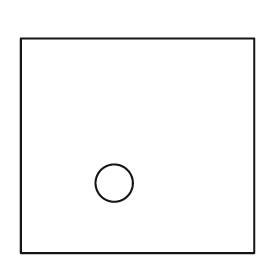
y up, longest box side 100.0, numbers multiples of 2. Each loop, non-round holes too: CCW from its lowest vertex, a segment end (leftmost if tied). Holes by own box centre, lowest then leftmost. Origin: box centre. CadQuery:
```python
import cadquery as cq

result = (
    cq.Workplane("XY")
    .moveTo(-50.0, -46.0)
    .lineTo(50.0, -46.0)
    .lineTo(50.0, 46.0)
    .lineTo(-50.0, 46.0)
    .close()
    .moveTo(-10.0, -16.0)
    .circle(8.0)
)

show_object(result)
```